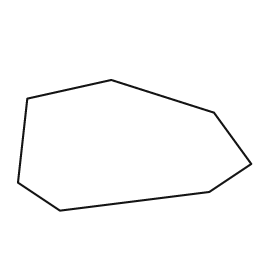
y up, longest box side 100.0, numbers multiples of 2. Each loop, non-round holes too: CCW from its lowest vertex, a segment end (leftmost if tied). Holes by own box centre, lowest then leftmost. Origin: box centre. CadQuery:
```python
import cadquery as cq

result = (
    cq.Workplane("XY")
    .moveTo(-32.0, -28.0)
    .lineTo(32.0, -20.0)
    .lineTo(50.0, -8.0)
    .lineTo(34.0, 14.0)
    .lineTo(-10.0, 28.0)
    .lineTo(-46.0, 20.0)
    .lineTo(-50.0, -16.0)
    .close()
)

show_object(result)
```